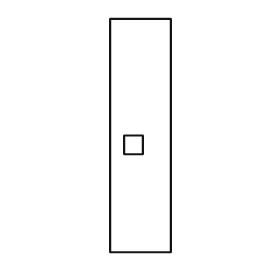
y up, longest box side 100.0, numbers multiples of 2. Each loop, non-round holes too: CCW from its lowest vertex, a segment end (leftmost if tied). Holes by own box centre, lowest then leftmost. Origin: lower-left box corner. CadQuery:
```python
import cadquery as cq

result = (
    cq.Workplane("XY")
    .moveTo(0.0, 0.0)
    .lineTo(26.0, 0.0)
    .lineTo(26.0, 100.0)
    .lineTo(0.0, 100.0)
    .close()
    .moveTo(6.0, 42.0)
    .lineTo(14.0, 42.0)
    .lineTo(14.0, 50.0)
    .lineTo(6.0, 50.0)
    .close()
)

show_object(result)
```